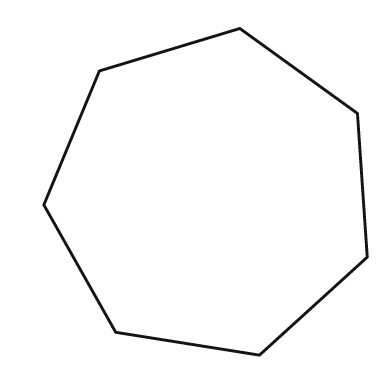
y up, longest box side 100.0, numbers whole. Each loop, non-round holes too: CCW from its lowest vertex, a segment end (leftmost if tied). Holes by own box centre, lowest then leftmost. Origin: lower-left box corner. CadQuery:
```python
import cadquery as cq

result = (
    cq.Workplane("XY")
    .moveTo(66.0, 0.0)
    .lineTo(99.0, 30.0)
    .lineTo(96.0, 74.0)
    .lineTo(60.0, 100.0)
    .lineTo(17.0, 87.0)
    .lineTo(0.0, 46.0)
    .lineTo(22.0, 7.0)
    .close()
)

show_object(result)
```